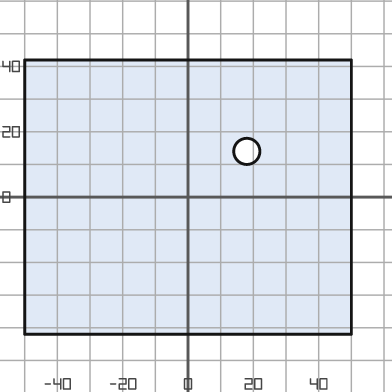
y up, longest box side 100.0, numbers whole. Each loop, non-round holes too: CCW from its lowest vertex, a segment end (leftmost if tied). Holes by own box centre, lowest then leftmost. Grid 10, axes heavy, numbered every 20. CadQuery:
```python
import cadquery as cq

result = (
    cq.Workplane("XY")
    .moveTo(-50.0, -42.0)
    .lineTo(50.0, -42.0)
    .lineTo(50.0, 42.0)
    .lineTo(-50.0, 42.0)
    .close()
    .moveTo(18.0, 14.0)
    .circle(4.0)
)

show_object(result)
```